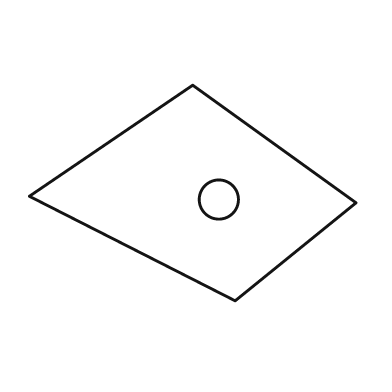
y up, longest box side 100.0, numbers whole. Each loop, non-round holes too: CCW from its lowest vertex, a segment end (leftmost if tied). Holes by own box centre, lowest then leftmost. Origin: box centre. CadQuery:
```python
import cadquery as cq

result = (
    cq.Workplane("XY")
    .moveTo(13.0, -33.0)
    .lineTo(50.0, -3.0)
    .lineTo(0.0, 33.0)
    .lineTo(-50.0, -1.0)
    .close()
    .moveTo(8.0, -2.0)
    .circle(6.0)
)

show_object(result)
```